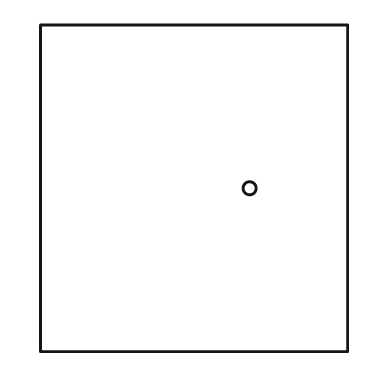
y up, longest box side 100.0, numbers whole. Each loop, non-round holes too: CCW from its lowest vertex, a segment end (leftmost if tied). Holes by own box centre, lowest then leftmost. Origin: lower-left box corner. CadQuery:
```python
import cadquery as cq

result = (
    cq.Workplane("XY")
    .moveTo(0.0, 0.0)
    .lineTo(94.0, 0.0)
    .lineTo(94.0, 100.0)
    .lineTo(0.0, 100.0)
    .close()
    .moveTo(64.0, 50.0)
    .circle(2.0)
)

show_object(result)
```